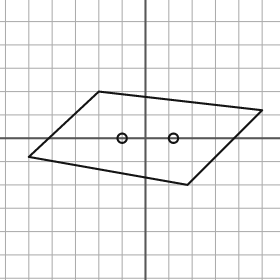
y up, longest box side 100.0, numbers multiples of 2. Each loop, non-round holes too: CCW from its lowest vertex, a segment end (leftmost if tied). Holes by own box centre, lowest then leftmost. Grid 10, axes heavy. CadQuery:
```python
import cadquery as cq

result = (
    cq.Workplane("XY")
    .moveTo(18.0, -20.0)
    .lineTo(50.0, 12.0)
    .lineTo(-20.0, 20.0)
    .lineTo(-50.0, -8.0)
    .close()
    .moveTo(-10.0, 0.0)
    .circle(2.0)
    .moveTo(12.0, 0.0)
    .circle(2.0)
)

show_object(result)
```